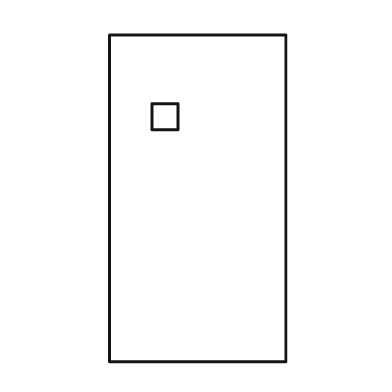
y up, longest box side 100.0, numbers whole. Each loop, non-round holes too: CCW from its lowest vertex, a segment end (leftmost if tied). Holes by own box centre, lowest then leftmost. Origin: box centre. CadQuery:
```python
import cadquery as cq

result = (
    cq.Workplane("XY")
    .moveTo(-27.0, -50.0)
    .lineTo(27.0, -50.0)
    .lineTo(27.0, 50.0)
    .lineTo(-27.0, 50.0)
    .close()
    .moveTo(-14.0, 21.0)
    .lineTo(-6.0, 21.0)
    .lineTo(-6.0, 29.0)
    .lineTo(-14.0, 29.0)
    .close()
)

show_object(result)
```